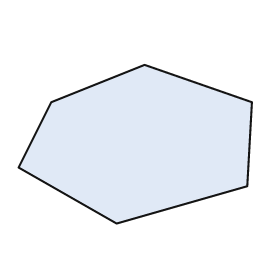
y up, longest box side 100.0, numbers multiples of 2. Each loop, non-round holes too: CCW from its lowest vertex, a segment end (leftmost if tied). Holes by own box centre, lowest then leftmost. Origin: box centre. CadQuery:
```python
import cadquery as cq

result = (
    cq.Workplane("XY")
    .moveTo(-8.0, -34.0)
    .lineTo(48.0, -18.0)
    .lineTo(50.0, 18.0)
    .lineTo(4.0, 34.0)
    .lineTo(-36.0, 18.0)
    .lineTo(-50.0, -10.0)
    .close()
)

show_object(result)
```